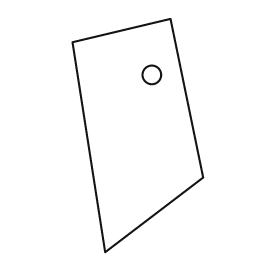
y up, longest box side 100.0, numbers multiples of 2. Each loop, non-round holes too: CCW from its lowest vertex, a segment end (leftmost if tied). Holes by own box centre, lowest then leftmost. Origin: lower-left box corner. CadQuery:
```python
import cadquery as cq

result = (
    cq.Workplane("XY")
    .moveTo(14.0, 0.0)
    .lineTo(56.0, 32.0)
    .lineTo(42.0, 100.0)
    .lineTo(0.0, 90.0)
    .close()
    .moveTo(34.0, 76.0)
    .circle(4.0)
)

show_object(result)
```